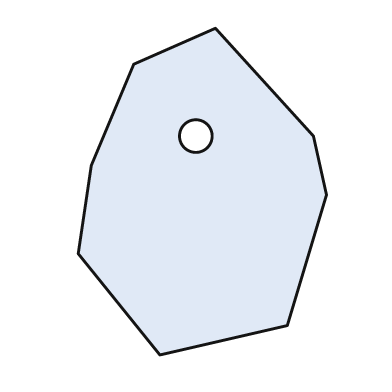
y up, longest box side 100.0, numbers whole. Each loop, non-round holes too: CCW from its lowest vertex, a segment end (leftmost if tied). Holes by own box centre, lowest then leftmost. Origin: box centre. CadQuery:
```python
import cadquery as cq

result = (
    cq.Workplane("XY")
    .moveTo(-13.0, -50.0)
    .lineTo(26.0, -41.0)
    .lineTo(38.0, -1.0)
    .lineTo(34.0, 17.0)
    .lineTo(4.0, 50.0)
    .lineTo(-21.0, 39.0)
    .lineTo(-34.0, 8.0)
    .lineTo(-38.0, -19.0)
    .close()
    .moveTo(-2.0, 17.0)
    .circle(5.0)
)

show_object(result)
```